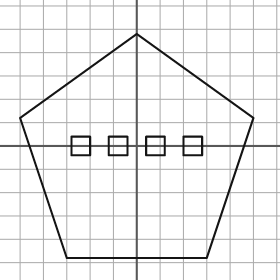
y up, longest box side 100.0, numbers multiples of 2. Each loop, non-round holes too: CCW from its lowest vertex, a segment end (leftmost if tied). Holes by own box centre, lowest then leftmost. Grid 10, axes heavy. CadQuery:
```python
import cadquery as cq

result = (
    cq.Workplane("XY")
    .moveTo(-30.0, -48.0)
    .lineTo(30.0, -48.0)
    .lineTo(50.0, 12.0)
    .lineTo(0.0, 48.0)
    .lineTo(-50.0, 12.0)
    .close()
    .moveTo(-28.0, -4.0)
    .lineTo(-20.0, -4.0)
    .lineTo(-20.0, 4.0)
    .lineTo(-28.0, 4.0)
    .close()
    .moveTo(-12.0, -4.0)
    .lineTo(-4.0, -4.0)
    .lineTo(-4.0, 4.0)
    .lineTo(-12.0, 4.0)
    .close()
    .moveTo(4.0, -4.0)
    .lineTo(12.0, -4.0)
    .lineTo(12.0, 4.0)
    .lineTo(4.0, 4.0)
    .close()
    .moveTo(20.0, -4.0)
    .lineTo(28.0, -4.0)
    .lineTo(28.0, 4.0)
    .lineTo(20.0, 4.0)
    .close()
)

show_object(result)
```